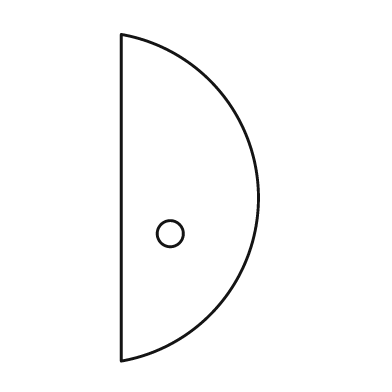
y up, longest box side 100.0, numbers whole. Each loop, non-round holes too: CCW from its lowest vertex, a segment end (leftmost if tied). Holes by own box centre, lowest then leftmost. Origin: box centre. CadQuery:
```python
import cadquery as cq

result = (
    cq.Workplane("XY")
    .moveTo(-21.0, -50.0)
    .threePointArc((21.0, 0.0), (-21.0, 50.0))
    .close()
    .moveTo(-6.0, -11.0)
    .circle(4.0)
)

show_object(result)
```